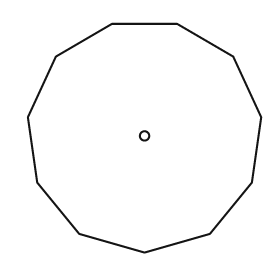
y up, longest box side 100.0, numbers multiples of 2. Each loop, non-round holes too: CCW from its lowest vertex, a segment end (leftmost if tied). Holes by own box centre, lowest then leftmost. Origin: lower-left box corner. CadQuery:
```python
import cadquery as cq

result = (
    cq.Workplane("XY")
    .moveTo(50.0, 0.0)
    .lineTo(78.0, 8.0)
    .lineTo(96.0, 30.0)
    .lineTo(100.0, 58.0)
    .lineTo(88.0, 84.0)
    .lineTo(64.0, 98.0)
    .lineTo(36.0, 98.0)
    .lineTo(12.0, 84.0)
    .lineTo(0.0, 58.0)
    .lineTo(4.0, 30.0)
    .lineTo(22.0, 8.0)
    .close()
    .moveTo(50.0, 50.0)
    .circle(2.0)
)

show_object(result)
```